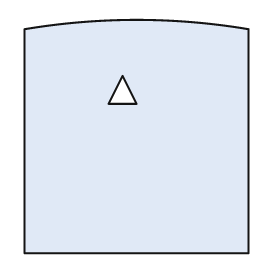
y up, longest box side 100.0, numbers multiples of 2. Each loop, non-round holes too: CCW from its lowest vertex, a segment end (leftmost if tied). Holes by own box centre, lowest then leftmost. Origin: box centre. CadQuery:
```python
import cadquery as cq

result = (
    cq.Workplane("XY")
    .moveTo(-48.0, -50.0)
    .lineTo(48.0, -50.0)
    .lineTo(48.0, 46.0)
    .threePointArc((0.0, 50.0), (-48.0, 46.0))
    .close()
    .moveTo(-12.0, 14.0)
    .lineTo(0.0, 14.0)
    .lineTo(-6.0, 26.0)
    .close()
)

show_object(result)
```